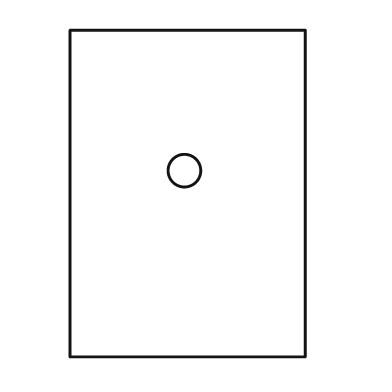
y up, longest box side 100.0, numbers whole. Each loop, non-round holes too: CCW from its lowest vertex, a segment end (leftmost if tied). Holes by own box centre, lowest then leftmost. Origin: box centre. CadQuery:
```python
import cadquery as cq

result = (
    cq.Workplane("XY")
    .moveTo(-36.0, -50.0)
    .lineTo(36.0, -50.0)
    .lineTo(36.0, 50.0)
    .lineTo(-36.0, 50.0)
    .close()
    .moveTo(-1.0, 7.0)
    .circle(5.0)
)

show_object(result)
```